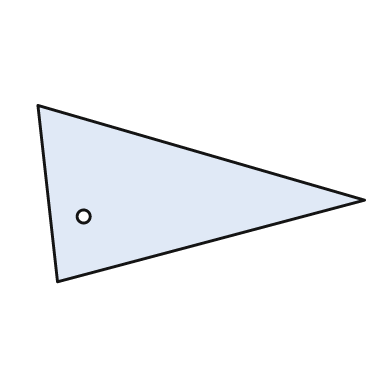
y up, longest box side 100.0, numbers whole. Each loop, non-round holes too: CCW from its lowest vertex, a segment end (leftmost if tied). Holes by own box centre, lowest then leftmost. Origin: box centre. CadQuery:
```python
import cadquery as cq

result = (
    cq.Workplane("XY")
    .moveTo(-44.0, -27.0)
    .lineTo(50.0, -2.0)
    .lineTo(-50.0, 27.0)
    .close()
    .moveTo(-36.0, -7.0)
    .circle(2.0)
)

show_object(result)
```